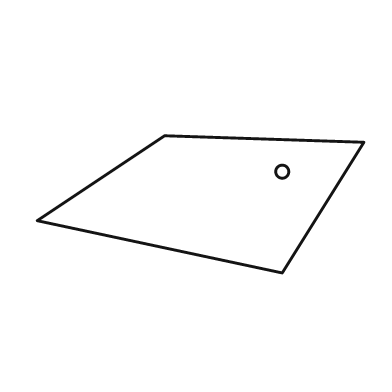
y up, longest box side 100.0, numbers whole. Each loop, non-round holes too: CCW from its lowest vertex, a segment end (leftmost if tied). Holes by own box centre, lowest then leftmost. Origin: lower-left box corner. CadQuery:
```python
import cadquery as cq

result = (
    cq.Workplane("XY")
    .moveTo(75.0, 0.0)
    .lineTo(100.0, 40.0)
    .lineTo(39.0, 42.0)
    .lineTo(0.0, 16.0)
    .close()
    .moveTo(75.0, 31.0)
    .circle(2.0)
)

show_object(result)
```